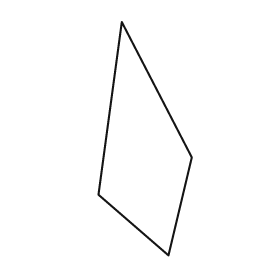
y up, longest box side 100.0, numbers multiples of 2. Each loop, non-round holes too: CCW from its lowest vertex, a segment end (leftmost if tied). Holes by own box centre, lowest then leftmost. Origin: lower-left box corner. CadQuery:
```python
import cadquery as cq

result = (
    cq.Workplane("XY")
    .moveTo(30.0, 0.0)
    .lineTo(40.0, 42.0)
    .lineTo(10.0, 100.0)
    .lineTo(0.0, 26.0)
    .close()
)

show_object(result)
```